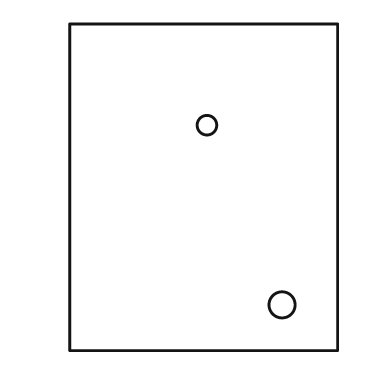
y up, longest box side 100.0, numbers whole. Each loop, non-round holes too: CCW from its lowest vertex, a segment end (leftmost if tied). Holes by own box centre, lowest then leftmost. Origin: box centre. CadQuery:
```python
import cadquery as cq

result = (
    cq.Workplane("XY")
    .moveTo(-41.0, -50.0)
    .lineTo(41.0, -50.0)
    .lineTo(41.0, 50.0)
    .lineTo(-41.0, 50.0)
    .close()
    .moveTo(24.0, -36.0)
    .circle(4.0)
    .moveTo(1.0, 19.0)
    .circle(3.0)
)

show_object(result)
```